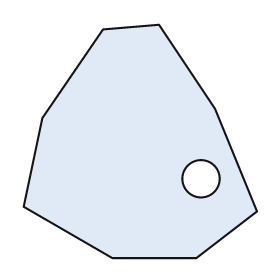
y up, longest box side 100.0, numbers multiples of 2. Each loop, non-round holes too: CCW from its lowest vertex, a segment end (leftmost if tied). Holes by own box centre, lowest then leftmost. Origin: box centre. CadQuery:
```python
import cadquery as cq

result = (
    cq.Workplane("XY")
    .moveTo(-12.0, -50.0)
    .lineTo(24.0, -50.0)
    .lineTo(50.0, -30.0)
    .lineTo(32.0, 14.0)
    .lineTo(8.0, 50.0)
    .lineTo(-16.0, 48.0)
    .lineTo(-42.0, 10.0)
    .lineTo(-50.0, -28.0)
    .close()
    .moveTo(26.0, -16.0)
    .circle(8.0)
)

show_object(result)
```